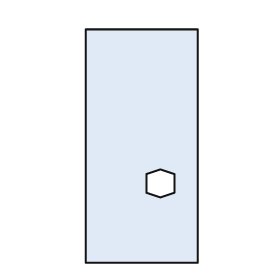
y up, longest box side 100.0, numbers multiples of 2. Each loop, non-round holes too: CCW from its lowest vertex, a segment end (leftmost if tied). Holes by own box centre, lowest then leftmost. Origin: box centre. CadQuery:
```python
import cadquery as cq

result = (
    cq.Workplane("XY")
    .moveTo(-24.0, -50.0)
    .lineTo(24.0, -50.0)
    .lineTo(24.0, 50.0)
    .lineTo(-24.0, 50.0)
    .close()
    .moveTo(8.0, -22.0)
    .lineTo(14.0, -20.0)
    .lineTo(14.0, -12.0)
    .lineTo(8.0, -10.0)
    .lineTo(2.0, -12.0)
    .lineTo(2.0, -20.0)
    .close()
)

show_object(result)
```